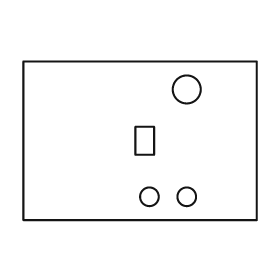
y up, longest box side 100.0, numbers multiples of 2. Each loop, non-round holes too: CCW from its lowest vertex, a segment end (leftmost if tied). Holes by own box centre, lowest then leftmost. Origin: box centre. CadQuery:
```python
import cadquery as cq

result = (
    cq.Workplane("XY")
    .moveTo(-50.0, -34.0)
    .lineTo(50.0, -34.0)
    .lineTo(50.0, 34.0)
    .lineTo(-50.0, 34.0)
    .close()
    .moveTo(4.0, -24.0)
    .circle(4.0)
    .moveTo(20.0, -24.0)
    .circle(4.0)
    .moveTo(-2.0, -6.0)
    .lineTo(6.0, -6.0)
    .lineTo(6.0, 6.0)
    .lineTo(-2.0, 6.0)
    .close()
    .moveTo(20.0, 22.0)
    .circle(6.0)
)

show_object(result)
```